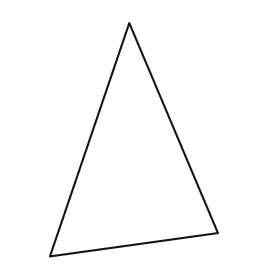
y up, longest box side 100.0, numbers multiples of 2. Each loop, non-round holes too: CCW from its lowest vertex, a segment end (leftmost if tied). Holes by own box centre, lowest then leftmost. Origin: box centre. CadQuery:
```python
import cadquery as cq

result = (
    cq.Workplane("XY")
    .moveTo(-36.0, -50.0)
    .lineTo(36.0, -40.0)
    .lineTo(-2.0, 50.0)
    .close()
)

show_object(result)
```